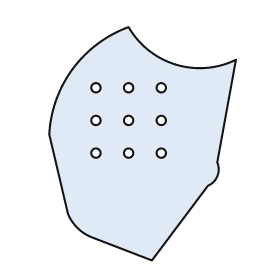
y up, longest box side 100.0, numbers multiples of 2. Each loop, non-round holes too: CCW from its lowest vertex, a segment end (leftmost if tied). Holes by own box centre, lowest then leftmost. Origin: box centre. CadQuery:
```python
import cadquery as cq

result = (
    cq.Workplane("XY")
    .moveTo(4.0, -50.0)
    .lineTo(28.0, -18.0)
    .threePointArc((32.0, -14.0), (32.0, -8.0))
    .lineTo(40.0, 36.0)
    .threePointArc((14.0, 34.0), (-6.0, 50.0))
    .threePointArc((-30.0, 32.0), (-40.0, 4.0))
    .lineTo(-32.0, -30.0)
    .threePointArc((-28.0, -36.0), (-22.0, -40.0))
    .close()
    .moveTo(-20.0, -4.0)
    .circle(2.0)
    .moveTo(-6.0, -4.0)
    .circle(2.0)
    .moveTo(8.0, -4.0)
    .circle(2.0)
    .moveTo(-20.0, 10.0)
    .circle(2.0)
    .moveTo(-6.0, 10.0)
    .circle(2.0)
    .moveTo(8.0, 10.0)
    .circle(2.0)
    .moveTo(-20.0, 24.0)
    .circle(2.0)
    .moveTo(-6.0, 24.0)
    .circle(2.0)
    .moveTo(8.0, 24.0)
    .circle(2.0)
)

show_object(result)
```